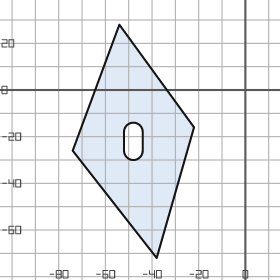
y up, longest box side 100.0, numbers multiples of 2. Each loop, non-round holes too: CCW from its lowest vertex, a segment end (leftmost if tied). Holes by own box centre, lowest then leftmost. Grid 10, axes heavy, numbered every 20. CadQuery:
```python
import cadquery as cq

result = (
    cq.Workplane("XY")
    .moveTo(-38.0, -72.0)
    .lineTo(-22.0, -16.0)
    .lineTo(-54.0, 28.0)
    .lineTo(-74.0, -26.0)
    .close()
    .moveTo(-52.0, -26.0)
    .threePointArc((-48.0, -30.0), (-44.0, -26.0))
    .lineTo(-44.0, -18.0)
    .threePointArc((-48.0, -14.0), (-52.0, -18.0))
    .close()
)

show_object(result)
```